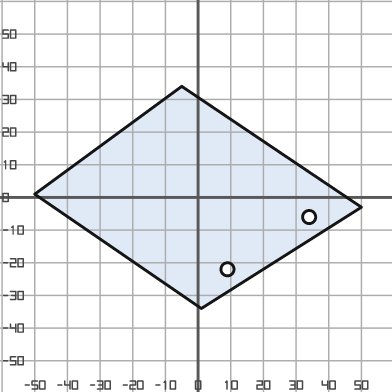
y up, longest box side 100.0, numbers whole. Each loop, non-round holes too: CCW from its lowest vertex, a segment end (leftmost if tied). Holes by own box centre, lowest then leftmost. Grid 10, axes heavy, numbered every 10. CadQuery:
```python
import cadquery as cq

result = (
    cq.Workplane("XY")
    .moveTo(1.0, -34.0)
    .lineTo(50.0, -3.0)
    .lineTo(-5.0, 34.0)
    .lineTo(-50.0, 1.0)
    .close()
    .moveTo(9.0, -22.0)
    .circle(2.0)
    .moveTo(34.0, -6.0)
    .circle(2.0)
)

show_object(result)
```